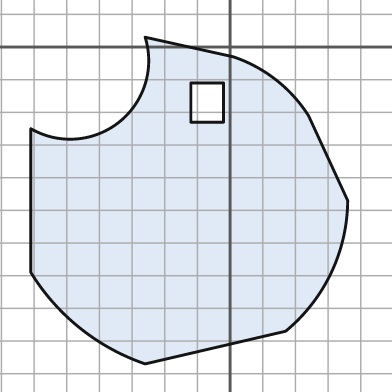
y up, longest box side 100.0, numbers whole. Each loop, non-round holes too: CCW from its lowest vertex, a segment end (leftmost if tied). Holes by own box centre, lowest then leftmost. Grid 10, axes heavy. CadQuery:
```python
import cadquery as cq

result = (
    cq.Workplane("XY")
    .moveTo(-26.0, -97.0)
    .lineTo(17.0, -87.0)
    .threePointArc((31.0, -69.0), (36.0, -47.0))
    .lineTo(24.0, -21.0)
    .threePointArc((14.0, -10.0), (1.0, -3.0))
    .lineTo(-26.0, 3.0)
    .threePointArc((-34.0, -23.0), (-61.0, -25.0))
    .lineTo(-61.0, -69.0)
    .threePointArc((-46.0, -86.0), (-26.0, -97.0))
    .close()
    .moveTo(-12.0, -23.0)
    .lineTo(-2.0, -23.0)
    .lineTo(-2.0, -11.0)
    .lineTo(-12.0, -11.0)
    .close()
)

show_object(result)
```